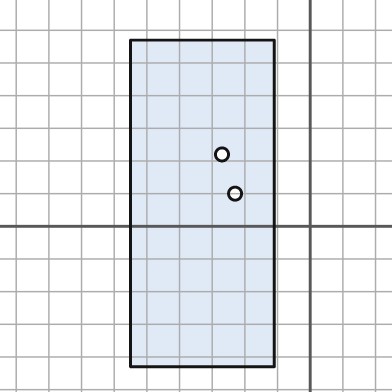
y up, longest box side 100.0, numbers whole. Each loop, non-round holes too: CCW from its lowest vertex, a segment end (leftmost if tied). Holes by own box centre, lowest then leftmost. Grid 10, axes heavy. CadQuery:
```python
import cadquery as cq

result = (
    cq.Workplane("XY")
    .moveTo(-55.0, -43.0)
    .lineTo(-11.0, -43.0)
    .lineTo(-11.0, 57.0)
    .lineTo(-55.0, 57.0)
    .close()
    .moveTo(-23.0, 10.0)
    .circle(2.0)
    .moveTo(-27.0, 22.0)
    .circle(2.0)
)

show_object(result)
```